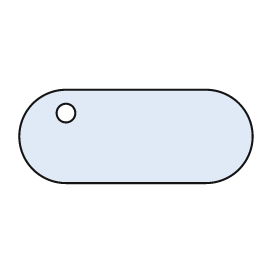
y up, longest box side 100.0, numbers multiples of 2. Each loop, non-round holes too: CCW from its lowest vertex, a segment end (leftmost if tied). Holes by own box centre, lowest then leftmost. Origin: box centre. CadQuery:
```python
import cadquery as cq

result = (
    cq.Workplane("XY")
    .moveTo(-30.0, -20.0)
    .lineTo(30.0, -20.0)
    .threePointArc((50.0, 0.0), (30.0, 20.0))
    .lineTo(-30.0, 20.0)
    .threePointArc((-50.0, 0.0), (-30.0, -20.0))
    .close()
    .moveTo(-30.0, 10.0)
    .circle(4.0)
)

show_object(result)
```